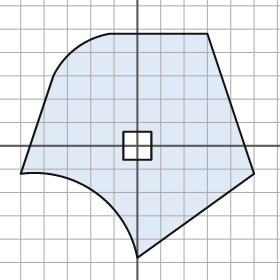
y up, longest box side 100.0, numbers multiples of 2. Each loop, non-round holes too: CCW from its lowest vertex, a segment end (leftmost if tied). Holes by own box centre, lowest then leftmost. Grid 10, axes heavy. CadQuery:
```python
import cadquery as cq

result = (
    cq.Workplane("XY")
    .moveTo(0.0, -48.0)
    .lineTo(50.0, -12.0)
    .lineTo(30.0, 48.0)
    .lineTo(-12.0, 48.0)
    .threePointArc((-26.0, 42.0), (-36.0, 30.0))
    .lineTo(-50.0, -12.0)
    .threePointArc((-18.0, -20.0), (0.0, -48.0))
    .close()
    .moveTo(-6.0, -6.0)
    .lineTo(6.0, -6.0)
    .lineTo(6.0, 6.0)
    .lineTo(-6.0, 6.0)
    .close()
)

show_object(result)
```